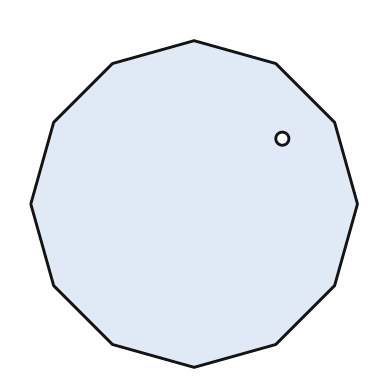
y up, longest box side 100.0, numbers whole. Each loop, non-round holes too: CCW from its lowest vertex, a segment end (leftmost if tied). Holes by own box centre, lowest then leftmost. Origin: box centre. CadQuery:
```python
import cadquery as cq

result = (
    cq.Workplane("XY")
    .moveTo(0.0, -50.0)
    .lineTo(25.0, -43.0)
    .lineTo(43.0, -25.0)
    .lineTo(50.0, 0.0)
    .lineTo(43.0, 25.0)
    .lineTo(25.0, 43.0)
    .lineTo(0.0, 50.0)
    .lineTo(-25.0, 43.0)
    .lineTo(-43.0, 25.0)
    .lineTo(-50.0, 0.0)
    .lineTo(-43.0, -25.0)
    .lineTo(-25.0, -43.0)
    .close()
    .moveTo(27.0, 20.0)
    .circle(2.0)
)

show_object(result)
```